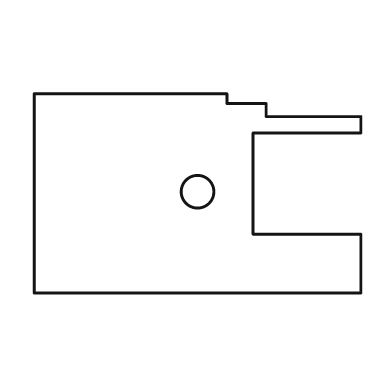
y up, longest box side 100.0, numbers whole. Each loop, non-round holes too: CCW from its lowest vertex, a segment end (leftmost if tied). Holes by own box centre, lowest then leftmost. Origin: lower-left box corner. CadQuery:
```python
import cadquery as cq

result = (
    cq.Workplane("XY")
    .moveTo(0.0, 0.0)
    .lineTo(100.0, 0.0)
    .lineTo(100.0, 18.0)
    .lineTo(67.0, 18.0)
    .lineTo(67.0, 49.0)
    .lineTo(100.0, 49.0)
    .lineTo(100.0, 54.0)
    .lineTo(71.0, 54.0)
    .lineTo(71.0, 58.0)
    .lineTo(59.0, 58.0)
    .lineTo(59.0, 61.0)
    .lineTo(0.0, 61.0)
    .close()
    .moveTo(50.0, 31.0)
    .circle(5.0)
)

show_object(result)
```